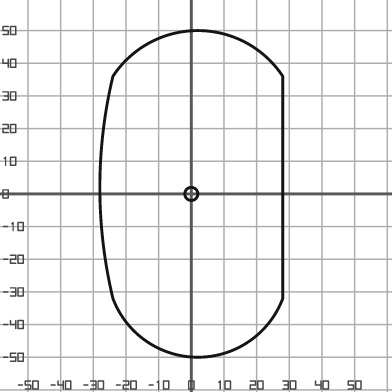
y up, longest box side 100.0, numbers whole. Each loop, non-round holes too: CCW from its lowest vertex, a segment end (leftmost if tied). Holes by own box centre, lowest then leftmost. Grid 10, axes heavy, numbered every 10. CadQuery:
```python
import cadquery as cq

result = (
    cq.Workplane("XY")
    .moveTo(-24.0, -32.0)
    .threePointArc((2.0, -50.0), (28.0, -32.0))
    .lineTo(28.0, 36.0)
    .threePointArc((2.0, 50.0), (-24.0, 36.0))
    .threePointArc((-28.0, 2.0), (-24.0, -32.0))
    .close()
    .moveTo(0.0, 0.0)
    .circle(2.0)
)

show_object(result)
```